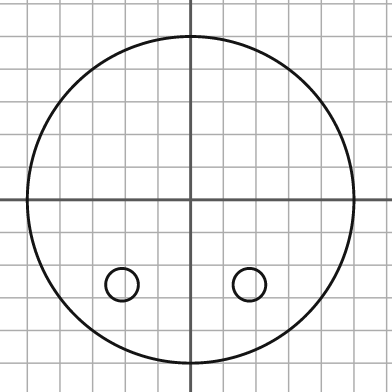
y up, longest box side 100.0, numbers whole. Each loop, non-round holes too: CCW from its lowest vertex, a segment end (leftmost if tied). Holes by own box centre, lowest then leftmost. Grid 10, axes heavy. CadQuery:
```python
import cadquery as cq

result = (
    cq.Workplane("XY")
    .moveTo(0.0, 0.0)
    .circle(50.0)
    .moveTo(-21.0, -26.0)
    .circle(5.0)
    .moveTo(18.0, -26.0)
    .circle(5.0)
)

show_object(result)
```